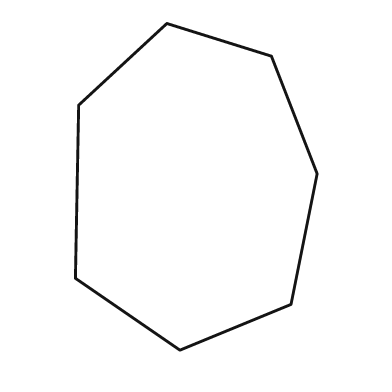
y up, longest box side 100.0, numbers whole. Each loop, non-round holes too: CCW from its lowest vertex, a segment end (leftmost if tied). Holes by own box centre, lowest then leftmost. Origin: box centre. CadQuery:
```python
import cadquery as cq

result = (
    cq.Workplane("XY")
    .moveTo(-5.0, -50.0)
    .lineTo(29.0, -36.0)
    .lineTo(37.0, 4.0)
    .lineTo(23.0, 40.0)
    .lineTo(-9.0, 50.0)
    .lineTo(-36.0, 25.0)
    .lineTo(-37.0, -28.0)
    .close()
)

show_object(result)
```